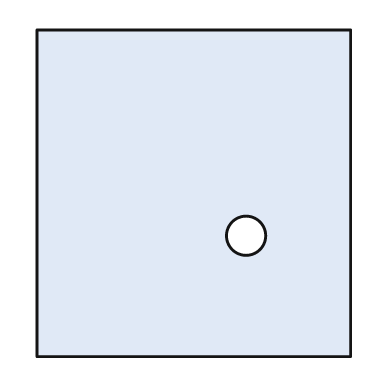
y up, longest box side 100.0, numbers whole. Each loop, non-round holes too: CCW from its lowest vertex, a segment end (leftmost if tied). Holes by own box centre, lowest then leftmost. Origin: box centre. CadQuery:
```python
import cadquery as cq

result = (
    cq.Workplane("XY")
    .moveTo(-48.0, -50.0)
    .lineTo(48.0, -50.0)
    .lineTo(48.0, 50.0)
    .lineTo(-48.0, 50.0)
    .close()
    .moveTo(16.0, -13.0)
    .circle(6.0)
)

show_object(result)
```